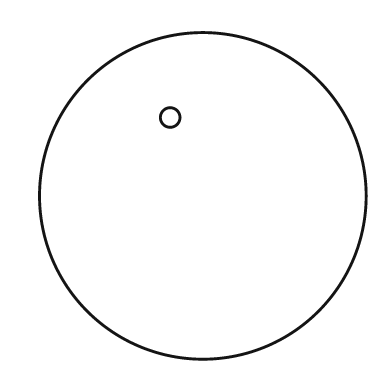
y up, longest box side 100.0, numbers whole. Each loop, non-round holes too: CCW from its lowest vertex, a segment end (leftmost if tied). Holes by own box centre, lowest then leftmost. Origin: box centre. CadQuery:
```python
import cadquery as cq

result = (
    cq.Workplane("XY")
    .moveTo(0.0, 0.0)
    .circle(50.0)
    .moveTo(-10.0, 24.0)
    .circle(3.0)
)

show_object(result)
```